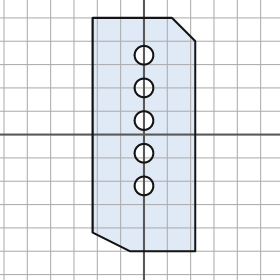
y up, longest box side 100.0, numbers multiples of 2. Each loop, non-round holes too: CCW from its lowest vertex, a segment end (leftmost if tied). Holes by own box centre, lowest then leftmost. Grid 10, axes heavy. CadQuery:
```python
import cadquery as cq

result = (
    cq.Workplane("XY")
    .moveTo(-6.0, -50.0)
    .lineTo(22.0, -50.0)
    .lineTo(22.0, 40.0)
    .lineTo(12.0, 50.0)
    .lineTo(-22.0, 50.0)
    .lineTo(-22.0, -42.0)
    .close()
    .moveTo(0.0, -22.0)
    .circle(4.0)
    .moveTo(0.0, -8.0)
    .circle(4.0)
    .moveTo(0.0, 6.0)
    .circle(4.0)
    .moveTo(0.0, 20.0)
    .circle(4.0)
    .moveTo(0.0, 34.0)
    .circle(4.0)
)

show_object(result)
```